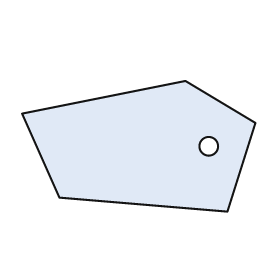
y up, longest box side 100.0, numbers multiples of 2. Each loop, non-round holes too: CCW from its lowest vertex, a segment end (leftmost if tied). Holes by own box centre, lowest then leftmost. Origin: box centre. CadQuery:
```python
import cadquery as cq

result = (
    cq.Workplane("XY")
    .moveTo(38.0, -28.0)
    .lineTo(50.0, 10.0)
    .lineTo(20.0, 28.0)
    .lineTo(-50.0, 14.0)
    .lineTo(-34.0, -22.0)
    .close()
    .moveTo(30.0, 0.0)
    .circle(4.0)
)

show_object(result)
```